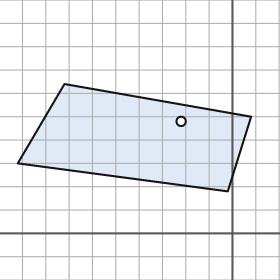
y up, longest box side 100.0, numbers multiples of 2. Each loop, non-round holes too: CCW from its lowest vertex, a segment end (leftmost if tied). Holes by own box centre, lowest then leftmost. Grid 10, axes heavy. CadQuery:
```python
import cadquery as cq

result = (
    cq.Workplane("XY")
    .moveTo(-2.0, 18.0)
    .lineTo(8.0, 50.0)
    .lineTo(-72.0, 64.0)
    .lineTo(-92.0, 30.0)
    .close()
    .moveTo(-22.0, 48.0)
    .circle(2.0)
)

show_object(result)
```